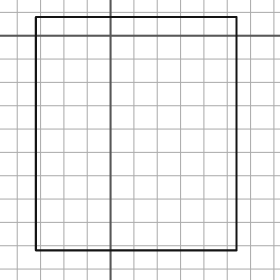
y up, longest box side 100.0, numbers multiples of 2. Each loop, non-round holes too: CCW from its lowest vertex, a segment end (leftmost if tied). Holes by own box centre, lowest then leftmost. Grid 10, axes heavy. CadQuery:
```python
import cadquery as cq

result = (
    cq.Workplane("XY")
    .moveTo(-32.0, -92.0)
    .lineTo(54.0, -92.0)
    .lineTo(54.0, 8.0)
    .lineTo(-32.0, 8.0)
    .close()
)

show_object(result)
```